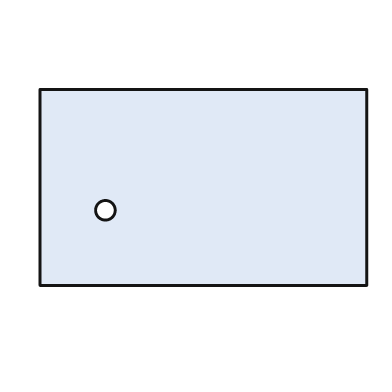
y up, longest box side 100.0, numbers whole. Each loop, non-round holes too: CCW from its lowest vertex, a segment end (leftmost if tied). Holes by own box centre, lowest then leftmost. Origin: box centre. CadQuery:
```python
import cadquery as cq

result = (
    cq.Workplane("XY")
    .moveTo(-50.0, -30.0)
    .lineTo(50.0, -30.0)
    .lineTo(50.0, 30.0)
    .lineTo(-50.0, 30.0)
    .close()
    .moveTo(-30.0, -7.0)
    .circle(3.0)
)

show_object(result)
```